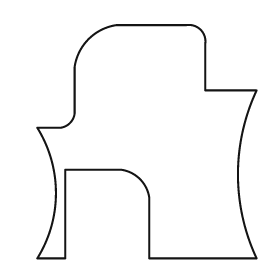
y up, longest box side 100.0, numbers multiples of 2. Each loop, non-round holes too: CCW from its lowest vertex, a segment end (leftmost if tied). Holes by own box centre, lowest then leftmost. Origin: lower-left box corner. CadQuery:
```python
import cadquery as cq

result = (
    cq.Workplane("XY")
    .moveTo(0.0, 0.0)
    .lineTo(12.0, 0.0)
    .lineTo(12.0, 38.0)
    .lineTo(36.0, 38.0)
    .threePointArc((44.0, 34.0), (48.0, 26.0))
    .lineTo(48.0, 0.0)
    .lineTo(94.0, 0.0)
    .threePointArc((86.0, 36.0), (94.0, 72.0))
    .lineTo(72.0, 72.0)
    .lineTo(72.0, 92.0)
    .threePointArc((70.0, 98.0), (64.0, 100.0))
    .lineTo(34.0, 100.0)
    .threePointArc((22.0, 94.0), (16.0, 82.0))
    .lineTo(16.0, 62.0)
    .threePointArc((14.0, 58.0), (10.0, 56.0))
    .lineTo(0.0, 56.0)
    .threePointArc((8.0, 28.0), (0.0, 0.0))
    .close()
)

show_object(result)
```